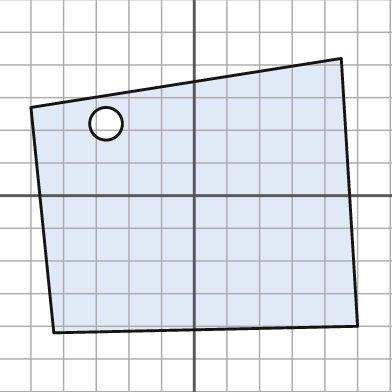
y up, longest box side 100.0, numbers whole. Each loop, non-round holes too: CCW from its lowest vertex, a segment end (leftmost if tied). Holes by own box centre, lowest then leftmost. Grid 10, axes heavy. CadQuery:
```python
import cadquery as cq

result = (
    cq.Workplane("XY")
    .moveTo(-43.0, -42.0)
    .lineTo(50.0, -40.0)
    .lineTo(45.0, 42.0)
    .lineTo(-50.0, 27.0)
    .close()
    .moveTo(-27.0, 22.0)
    .circle(5.0)
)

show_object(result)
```